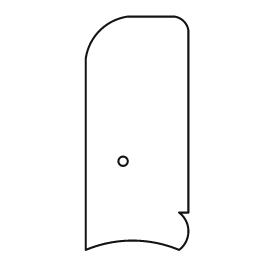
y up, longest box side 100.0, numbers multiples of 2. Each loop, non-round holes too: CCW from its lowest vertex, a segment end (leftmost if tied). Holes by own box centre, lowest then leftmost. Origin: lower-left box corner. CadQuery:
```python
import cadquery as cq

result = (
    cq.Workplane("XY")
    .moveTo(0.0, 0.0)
    .threePointArc((20.0, 4.0), (40.0, 0.0))
    .threePointArc((44.0, 8.0), (40.0, 16.0))
    .lineTo(44.0, 16.0)
    .lineTo(44.0, 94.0)
    .threePointArc((42.0, 98.0), (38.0, 100.0))
    .lineTo(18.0, 100.0)
    .threePointArc((6.0, 94.0), (0.0, 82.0))
    .close()
    .moveTo(16.0, 38.0)
    .circle(2.0)
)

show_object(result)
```